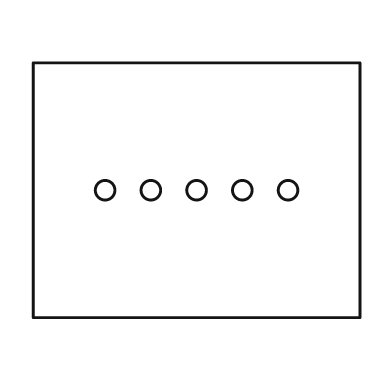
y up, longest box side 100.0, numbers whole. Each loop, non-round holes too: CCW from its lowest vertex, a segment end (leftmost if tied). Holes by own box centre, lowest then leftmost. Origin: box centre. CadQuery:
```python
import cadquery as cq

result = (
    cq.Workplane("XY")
    .moveTo(-50.0, -39.0)
    .lineTo(50.0, -39.0)
    .lineTo(50.0, 39.0)
    .lineTo(-50.0, 39.0)
    .close()
    .moveTo(-28.0, 0.0)
    .circle(3.0)
    .moveTo(-14.0, 0.0)
    .circle(3.0)
    .moveTo(0.0, 0.0)
    .circle(3.0)
    .moveTo(14.0, 0.0)
    .circle(3.0)
    .moveTo(28.0, 0.0)
    .circle(3.0)
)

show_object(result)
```